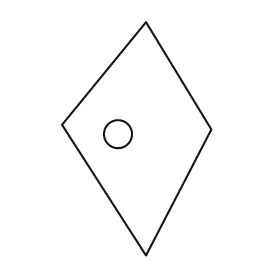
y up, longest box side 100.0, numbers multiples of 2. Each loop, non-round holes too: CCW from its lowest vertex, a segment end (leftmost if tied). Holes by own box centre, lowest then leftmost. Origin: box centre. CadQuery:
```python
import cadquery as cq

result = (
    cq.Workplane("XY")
    .moveTo(4.0, -50.0)
    .lineTo(32.0, 4.0)
    .lineTo(4.0, 50.0)
    .lineTo(-32.0, 6.0)
    .close()
    .moveTo(-8.0, 2.0)
    .circle(6.0)
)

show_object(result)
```